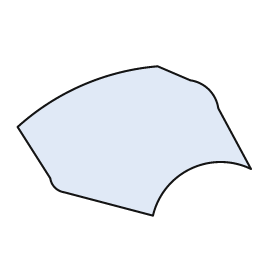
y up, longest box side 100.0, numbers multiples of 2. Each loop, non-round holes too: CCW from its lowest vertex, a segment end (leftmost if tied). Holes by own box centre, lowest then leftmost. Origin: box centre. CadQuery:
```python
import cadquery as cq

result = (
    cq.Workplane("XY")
    .moveTo(8.0, -32.0)
    .threePointArc((24.0, -12.0), (50.0, -12.0))
    .lineTo(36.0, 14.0)
    .threePointArc((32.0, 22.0), (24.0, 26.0))
    .lineTo(10.0, 32.0)
    .threePointArc((-22.0, 24.0), (-50.0, 6.0))
    .lineTo(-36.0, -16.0)
    .threePointArc((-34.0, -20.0), (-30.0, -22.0))
    .close()
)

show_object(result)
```